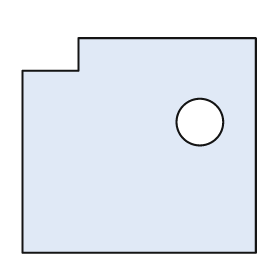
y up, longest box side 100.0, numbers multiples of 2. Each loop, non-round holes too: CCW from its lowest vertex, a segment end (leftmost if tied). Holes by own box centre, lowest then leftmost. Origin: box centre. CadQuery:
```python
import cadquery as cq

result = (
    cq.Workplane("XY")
    .moveTo(-50.0, -46.0)
    .lineTo(50.0, -46.0)
    .lineTo(50.0, 46.0)
    .lineTo(-26.0, 46.0)
    .lineTo(-26.0, 32.0)
    .lineTo(-50.0, 32.0)
    .close()
    .moveTo(26.0, 10.0)
    .circle(10.0)
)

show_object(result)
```